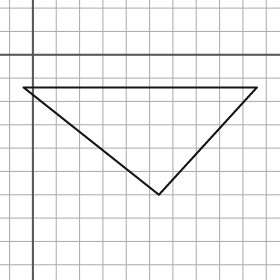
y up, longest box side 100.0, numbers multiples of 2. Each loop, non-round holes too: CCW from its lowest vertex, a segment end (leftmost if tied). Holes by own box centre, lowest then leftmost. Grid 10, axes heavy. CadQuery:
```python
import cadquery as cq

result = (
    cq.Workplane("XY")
    .moveTo(54.0, -60.0)
    .lineTo(96.0, -14.0)
    .lineTo(-4.0, -14.0)
    .close()
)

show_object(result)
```